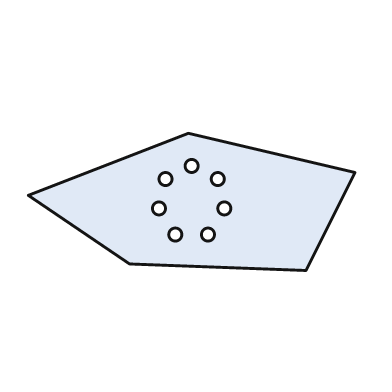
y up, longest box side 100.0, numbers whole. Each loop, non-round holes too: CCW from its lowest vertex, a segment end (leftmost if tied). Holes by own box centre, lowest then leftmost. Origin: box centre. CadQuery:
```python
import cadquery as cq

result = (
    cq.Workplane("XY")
    .moveTo(35.0, -21.0)
    .lineTo(50.0, 9.0)
    .lineTo(-1.0, 21.0)
    .lineTo(-50.0, 2.0)
    .lineTo(-19.0, -19.0)
    .close()
    .moveTo(-5.0, -10.0)
    .circle(2.0)
    .moveTo(5.0, -10.0)
    .circle(2.0)
    .moveTo(-10.0, -2.0)
    .circle(2.0)
    .moveTo(10.0, -2.0)
    .circle(2.0)
    .moveTo(-8.0, 7.0)
    .circle(2.0)
    .moveTo(8.0, 7.0)
    .circle(2.0)
    .moveTo(0.0, 11.0)
    .circle(2.0)
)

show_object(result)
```